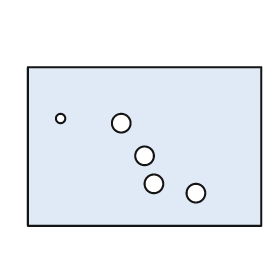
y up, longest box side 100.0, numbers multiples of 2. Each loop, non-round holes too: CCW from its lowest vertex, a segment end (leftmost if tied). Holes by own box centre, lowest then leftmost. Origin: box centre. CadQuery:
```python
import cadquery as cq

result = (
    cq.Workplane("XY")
    .moveTo(-50.0, -34.0)
    .lineTo(50.0, -34.0)
    .lineTo(50.0, 34.0)
    .lineTo(-50.0, 34.0)
    .close()
    .moveTo(22.0, -20.0)
    .circle(4.0)
    .moveTo(4.0, -16.0)
    .circle(4.0)
    .moveTo(0.0, -4.0)
    .circle(4.0)
    .moveTo(-10.0, 10.0)
    .circle(4.0)
    .moveTo(-36.0, 12.0)
    .circle(2.0)
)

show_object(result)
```